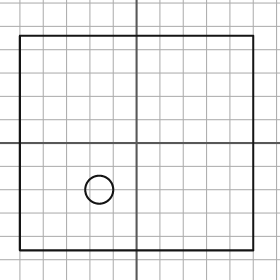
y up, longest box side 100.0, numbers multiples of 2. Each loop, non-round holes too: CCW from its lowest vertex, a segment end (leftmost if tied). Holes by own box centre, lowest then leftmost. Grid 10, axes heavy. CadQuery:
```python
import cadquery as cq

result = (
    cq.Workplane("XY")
    .moveTo(-50.0, -46.0)
    .lineTo(50.0, -46.0)
    .lineTo(50.0, 46.0)
    .lineTo(-50.0, 46.0)
    .close()
    .moveTo(-16.0, -20.0)
    .circle(6.0)
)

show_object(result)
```